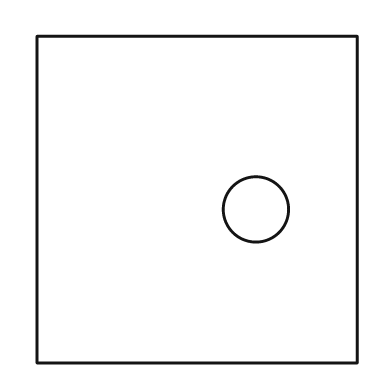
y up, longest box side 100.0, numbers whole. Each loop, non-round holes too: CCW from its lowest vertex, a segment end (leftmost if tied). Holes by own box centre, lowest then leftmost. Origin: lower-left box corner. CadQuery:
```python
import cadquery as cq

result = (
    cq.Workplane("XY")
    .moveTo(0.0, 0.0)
    .lineTo(98.0, 0.0)
    .lineTo(98.0, 100.0)
    .lineTo(0.0, 100.0)
    .close()
    .moveTo(67.0, 47.0)
    .circle(10.0)
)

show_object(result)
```